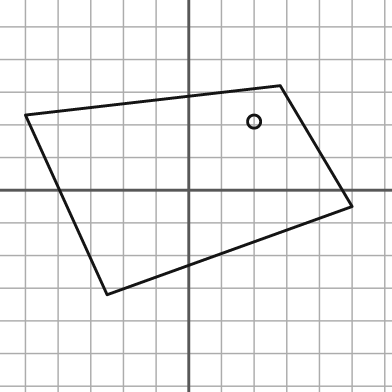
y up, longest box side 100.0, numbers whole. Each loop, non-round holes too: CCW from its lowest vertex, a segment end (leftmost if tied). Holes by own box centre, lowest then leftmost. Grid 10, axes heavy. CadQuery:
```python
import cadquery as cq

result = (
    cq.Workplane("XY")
    .moveTo(-25.0, -32.0)
    .lineTo(50.0, -5.0)
    .lineTo(28.0, 32.0)
    .lineTo(-50.0, 23.0)
    .close()
    .moveTo(20.0, 21.0)
    .circle(2.0)
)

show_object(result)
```